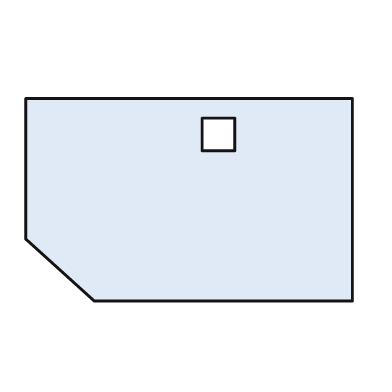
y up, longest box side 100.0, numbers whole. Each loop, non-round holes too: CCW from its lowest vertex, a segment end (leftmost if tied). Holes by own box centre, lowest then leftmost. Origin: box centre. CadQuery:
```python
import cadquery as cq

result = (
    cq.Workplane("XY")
    .moveTo(-29.0, -31.0)
    .lineTo(50.0, -31.0)
    .lineTo(50.0, 31.0)
    .lineTo(-50.0, 31.0)
    .lineTo(-50.0, -12.0)
    .close()
    .moveTo(4.0, 15.0)
    .lineTo(14.0, 15.0)
    .lineTo(14.0, 25.0)
    .lineTo(4.0, 25.0)
    .close()
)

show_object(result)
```